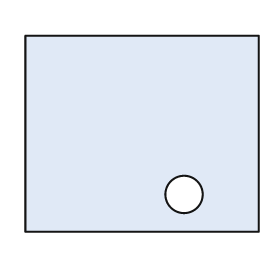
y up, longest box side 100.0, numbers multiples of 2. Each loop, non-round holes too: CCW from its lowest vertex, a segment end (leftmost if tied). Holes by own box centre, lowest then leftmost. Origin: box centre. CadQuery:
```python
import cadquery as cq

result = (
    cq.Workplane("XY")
    .moveTo(-50.0, -42.0)
    .lineTo(50.0, -42.0)
    .lineTo(50.0, 42.0)
    .lineTo(-50.0, 42.0)
    .close()
    .moveTo(18.0, -26.0)
    .circle(8.0)
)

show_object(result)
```